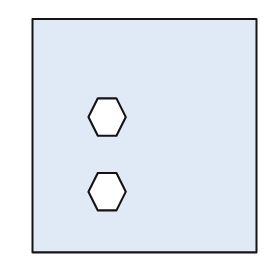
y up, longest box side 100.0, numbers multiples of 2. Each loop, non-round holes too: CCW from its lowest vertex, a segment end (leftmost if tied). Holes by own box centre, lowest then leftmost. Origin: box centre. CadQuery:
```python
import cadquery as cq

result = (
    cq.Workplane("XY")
    .moveTo(-48.0, -50.0)
    .lineTo(48.0, -50.0)
    .lineTo(48.0, 50.0)
    .lineTo(-48.0, 50.0)
    .close()
    .moveTo(-20.0, -32.0)
    .lineTo(-12.0, -32.0)
    .lineTo(-8.0, -24.0)
    .lineTo(-12.0, -16.0)
    .lineTo(-20.0, -16.0)
    .lineTo(-24.0, -24.0)
    .close()
    .moveTo(-20.0, 0.0)
    .lineTo(-12.0, 0.0)
    .lineTo(-8.0, 8.0)
    .lineTo(-12.0, 16.0)
    .lineTo(-20.0, 16.0)
    .lineTo(-24.0, 8.0)
    .close()
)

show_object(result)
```